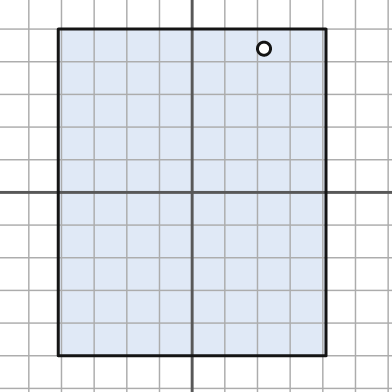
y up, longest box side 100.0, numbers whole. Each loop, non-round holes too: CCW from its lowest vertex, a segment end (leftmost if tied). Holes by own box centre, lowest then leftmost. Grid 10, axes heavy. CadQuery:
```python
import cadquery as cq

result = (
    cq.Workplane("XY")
    .moveTo(-41.0, -50.0)
    .lineTo(41.0, -50.0)
    .lineTo(41.0, 50.0)
    .lineTo(-41.0, 50.0)
    .close()
    .moveTo(22.0, 44.0)
    .circle(2.0)
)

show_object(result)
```